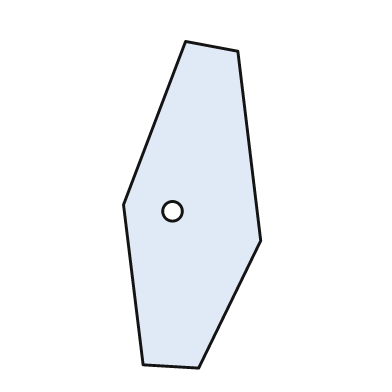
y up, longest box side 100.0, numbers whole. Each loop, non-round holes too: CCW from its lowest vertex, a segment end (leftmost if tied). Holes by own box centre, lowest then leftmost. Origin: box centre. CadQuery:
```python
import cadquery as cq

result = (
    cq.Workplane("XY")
    .moveTo(2.0, -50.0)
    .lineTo(21.0, -11.0)
    .lineTo(14.0, 47.0)
    .lineTo(-2.0, 50.0)
    .lineTo(-21.0, 0.0)
    .lineTo(-15.0, -49.0)
    .close()
    .moveTo(-6.0, -2.0)
    .circle(3.0)
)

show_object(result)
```